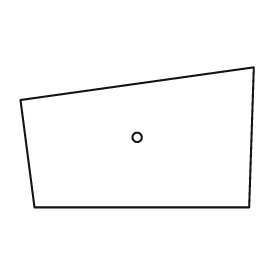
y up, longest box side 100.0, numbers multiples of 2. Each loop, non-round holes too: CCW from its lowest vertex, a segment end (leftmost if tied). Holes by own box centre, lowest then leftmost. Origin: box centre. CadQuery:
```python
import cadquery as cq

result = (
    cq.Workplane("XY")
    .moveTo(-44.0, -30.0)
    .lineTo(48.0, -30.0)
    .lineTo(50.0, 30.0)
    .lineTo(-50.0, 16.0)
    .close()
    .moveTo(0.0, 0.0)
    .circle(2.0)
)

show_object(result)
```